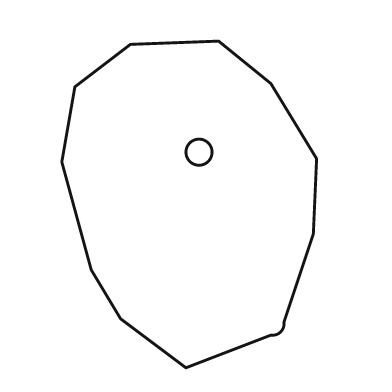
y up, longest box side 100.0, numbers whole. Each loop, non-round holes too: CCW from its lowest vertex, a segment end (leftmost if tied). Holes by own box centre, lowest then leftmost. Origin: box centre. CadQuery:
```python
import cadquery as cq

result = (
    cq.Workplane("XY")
    .moveTo(-1.0, -50.0)
    .lineTo(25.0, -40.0)
    .threePointArc((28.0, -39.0), (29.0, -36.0))
    .lineTo(38.0, -9.0)
    .lineTo(39.0, 14.0)
    .lineTo(25.0, 37.0)
    .lineTo(9.0, 50.0)
    .lineTo(-18.0, 49.0)
    .lineTo(-35.0, 36.0)
    .lineTo(-39.0, 13.0)
    .lineTo(-30.0, -20.0)
    .lineTo(-21.0, -35.0)
    .close()
    .moveTo(3.0, 16.0)
    .circle(4.0)
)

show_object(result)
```